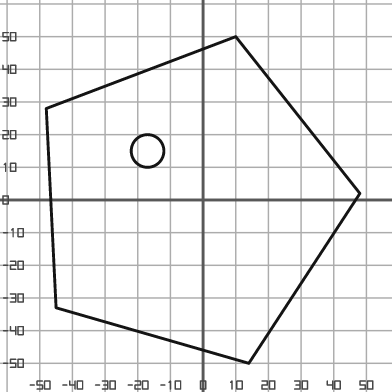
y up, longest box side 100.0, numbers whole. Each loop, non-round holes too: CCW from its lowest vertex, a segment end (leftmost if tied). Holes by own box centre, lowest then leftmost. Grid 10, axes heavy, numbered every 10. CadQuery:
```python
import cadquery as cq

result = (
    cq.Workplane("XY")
    .moveTo(14.0, -50.0)
    .lineTo(48.0, 2.0)
    .lineTo(10.0, 50.0)
    .lineTo(-48.0, 28.0)
    .lineTo(-45.0, -33.0)
    .close()
    .moveTo(-17.0, 15.0)
    .circle(5.0)
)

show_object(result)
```